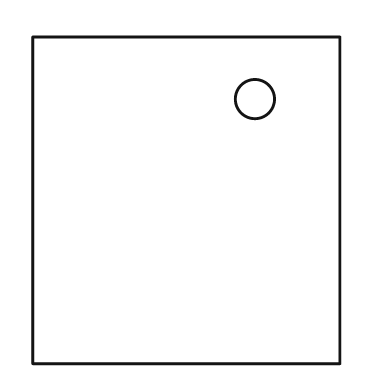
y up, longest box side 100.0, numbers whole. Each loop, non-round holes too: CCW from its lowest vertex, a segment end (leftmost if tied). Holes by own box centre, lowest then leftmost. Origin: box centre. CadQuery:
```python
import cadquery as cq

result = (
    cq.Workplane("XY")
    .moveTo(-47.0, -50.0)
    .lineTo(47.0, -50.0)
    .lineTo(47.0, 50.0)
    .lineTo(-47.0, 50.0)
    .close()
    .moveTo(21.0, 31.0)
    .circle(6.0)
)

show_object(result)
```